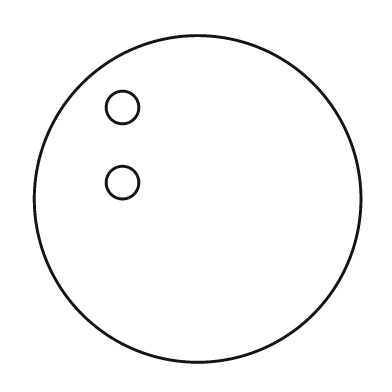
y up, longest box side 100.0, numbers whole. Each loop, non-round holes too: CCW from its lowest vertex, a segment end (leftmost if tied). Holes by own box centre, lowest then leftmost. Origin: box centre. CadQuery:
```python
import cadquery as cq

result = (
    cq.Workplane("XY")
    .moveTo(0.0, 0.0)
    .circle(50.0)
    .moveTo(-23.0, 5.0)
    .circle(5.0)
    .moveTo(-23.0, 28.0)
    .circle(5.0)
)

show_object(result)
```